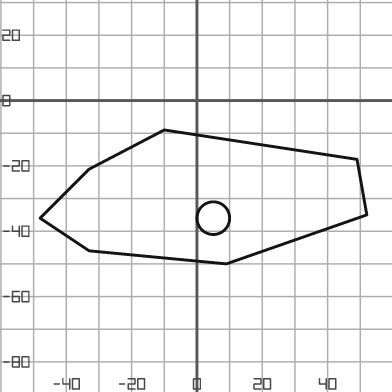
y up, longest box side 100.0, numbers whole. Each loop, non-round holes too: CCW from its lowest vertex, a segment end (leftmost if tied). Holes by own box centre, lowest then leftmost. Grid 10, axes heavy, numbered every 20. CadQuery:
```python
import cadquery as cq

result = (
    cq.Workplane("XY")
    .moveTo(9.0, -50.0)
    .lineTo(52.0, -35.0)
    .lineTo(49.0, -18.0)
    .lineTo(-10.0, -9.0)
    .lineTo(-33.0, -21.0)
    .lineTo(-48.0, -36.0)
    .lineTo(-33.0, -46.0)
    .close()
    .moveTo(5.0, -36.0)
    .circle(5.0)
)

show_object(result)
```